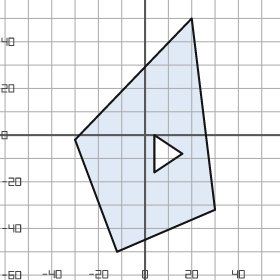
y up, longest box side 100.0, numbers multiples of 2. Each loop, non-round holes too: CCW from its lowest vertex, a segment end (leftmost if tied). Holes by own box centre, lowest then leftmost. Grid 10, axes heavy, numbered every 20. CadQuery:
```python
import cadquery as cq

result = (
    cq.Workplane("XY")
    .moveTo(-12.0, -50.0)
    .lineTo(30.0, -32.0)
    .lineTo(20.0, 50.0)
    .lineTo(-30.0, -2.0)
    .close()
    .moveTo(4.0, -16.0)
    .lineTo(16.0, -8.0)
    .lineTo(4.0, 0.0)
    .close()
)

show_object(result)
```